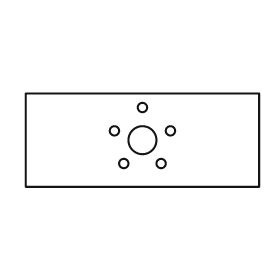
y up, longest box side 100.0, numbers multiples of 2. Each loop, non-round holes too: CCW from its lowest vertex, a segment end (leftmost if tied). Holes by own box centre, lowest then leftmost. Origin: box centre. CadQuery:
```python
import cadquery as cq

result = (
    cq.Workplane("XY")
    .moveTo(-50.0, -20.0)
    .lineTo(50.0, -20.0)
    .lineTo(50.0, 20.0)
    .lineTo(-50.0, 20.0)
    .close()
    .moveTo(-8.0, -10.0)
    .circle(2.0)
    .moveTo(8.0, -10.0)
    .circle(2.0)
    .moveTo(0.0, 0.0)
    .circle(6.0)
    .moveTo(-12.0, 4.0)
    .circle(2.0)
    .moveTo(12.0, 4.0)
    .circle(2.0)
    .moveTo(0.0, 14.0)
    .circle(2.0)
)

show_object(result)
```